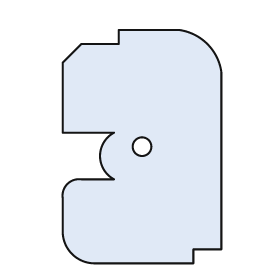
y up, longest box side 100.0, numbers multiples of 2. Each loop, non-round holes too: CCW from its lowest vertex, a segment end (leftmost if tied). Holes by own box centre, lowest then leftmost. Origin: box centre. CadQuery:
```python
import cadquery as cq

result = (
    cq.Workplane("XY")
    .moveTo(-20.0, -50.0)
    .lineTo(22.0, -50.0)
    .lineTo(22.0, -44.0)
    .lineTo(34.0, -44.0)
    .lineTo(34.0, 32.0)
    .threePointArc((28.0, 44.0), (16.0, 50.0))
    .lineTo(-10.0, 50.0)
    .lineTo(-10.0, 44.0)
    .lineTo(-26.0, 44.0)
    .lineTo(-34.0, 36.0)
    .lineTo(-34.0, 6.0)
    .lineTo(-12.0, 6.0)
    .threePointArc((-18.0, -4.0), (-12.0, -14.0))
    .lineTo(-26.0, -14.0)
    .threePointArc((-32.0, -16.0), (-34.0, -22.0))
    .lineTo(-34.0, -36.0)
    .threePointArc((-30.0, -46.0), (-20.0, -50.0))
    .close()
    .moveTo(0.0, 0.0)
    .circle(4.0)
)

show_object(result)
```